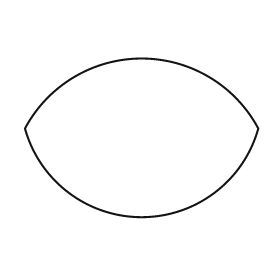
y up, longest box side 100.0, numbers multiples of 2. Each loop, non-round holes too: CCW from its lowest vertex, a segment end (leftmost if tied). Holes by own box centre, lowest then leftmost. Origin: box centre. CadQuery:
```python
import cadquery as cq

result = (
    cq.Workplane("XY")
    .moveTo(-50.0, 4.0)
    .threePointArc((0.0, -34.0), (50.0, 4.0))
    .threePointArc((0.0, 34.0), (-50.0, 4.0))
    .close()
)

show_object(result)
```